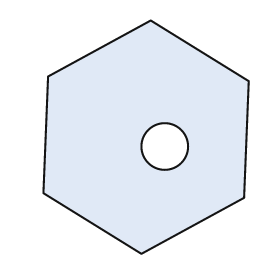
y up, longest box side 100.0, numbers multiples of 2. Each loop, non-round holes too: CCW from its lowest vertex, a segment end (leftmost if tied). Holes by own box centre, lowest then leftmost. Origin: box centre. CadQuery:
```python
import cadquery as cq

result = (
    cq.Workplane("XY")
    .moveTo(-2.0, -50.0)
    .lineTo(42.0, -26.0)
    .lineTo(44.0, 24.0)
    .lineTo(2.0, 50.0)
    .lineTo(-42.0, 26.0)
    .lineTo(-44.0, -24.0)
    .close()
    .moveTo(8.0, -4.0)
    .circle(10.0)
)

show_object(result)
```